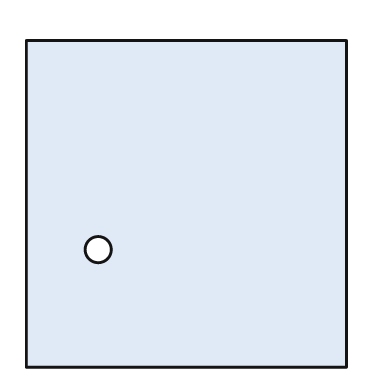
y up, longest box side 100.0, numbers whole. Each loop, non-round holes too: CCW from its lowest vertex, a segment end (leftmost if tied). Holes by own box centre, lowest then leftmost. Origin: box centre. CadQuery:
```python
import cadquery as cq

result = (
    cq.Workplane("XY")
    .moveTo(-49.0, -50.0)
    .lineTo(49.0, -50.0)
    .lineTo(49.0, 50.0)
    .lineTo(-49.0, 50.0)
    .close()
    .moveTo(-27.0, -14.0)
    .circle(4.0)
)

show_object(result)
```